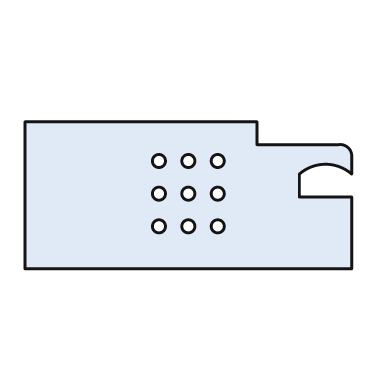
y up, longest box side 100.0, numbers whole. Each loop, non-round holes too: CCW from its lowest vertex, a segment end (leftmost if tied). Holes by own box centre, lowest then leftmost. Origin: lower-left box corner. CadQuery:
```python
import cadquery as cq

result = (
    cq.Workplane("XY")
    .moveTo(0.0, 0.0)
    .lineTo(100.0, 0.0)
    .lineTo(100.0, 22.0)
    .lineTo(84.0, 22.0)
    .lineTo(84.0, 29.0)
    .threePointArc((92.0, 32.0), (100.0, 29.0))
    .lineTo(100.0, 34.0)
    .threePointArc((99.0, 37.0), (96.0, 38.0))
    .lineTo(71.0, 38.0)
    .lineTo(71.0, 45.0)
    .lineTo(0.0, 45.0)
    .close()
    .moveTo(41.0, 13.0)
    .circle(2.0)
    .moveTo(50.0, 13.0)
    .circle(2.0)
    .moveTo(59.0, 13.0)
    .circle(2.0)
    .moveTo(41.0, 23.0)
    .circle(2.0)
    .moveTo(50.0, 23.0)
    .circle(2.0)
    .moveTo(59.0, 23.0)
    .circle(2.0)
    .moveTo(41.0, 33.0)
    .circle(2.0)
    .moveTo(50.0, 33.0)
    .circle(2.0)
    .moveTo(59.0, 33.0)
    .circle(2.0)
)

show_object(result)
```